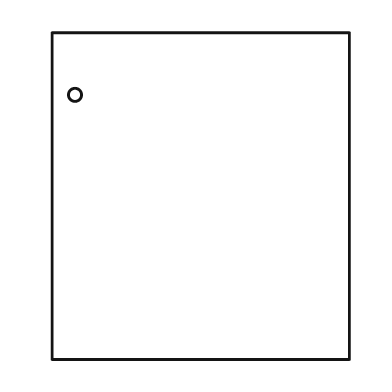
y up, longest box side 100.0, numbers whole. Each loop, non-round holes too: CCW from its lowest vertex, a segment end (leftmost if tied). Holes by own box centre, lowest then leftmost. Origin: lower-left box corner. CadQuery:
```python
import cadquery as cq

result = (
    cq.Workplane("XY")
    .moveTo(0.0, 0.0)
    .lineTo(91.0, 0.0)
    .lineTo(91.0, 100.0)
    .lineTo(0.0, 100.0)
    .close()
    .moveTo(7.0, 81.0)
    .circle(2.0)
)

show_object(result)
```